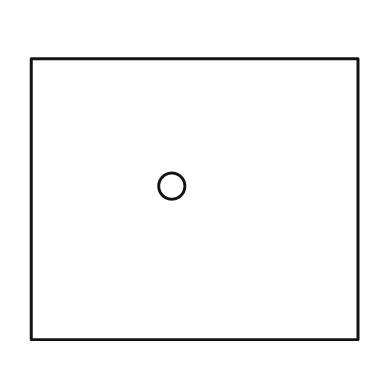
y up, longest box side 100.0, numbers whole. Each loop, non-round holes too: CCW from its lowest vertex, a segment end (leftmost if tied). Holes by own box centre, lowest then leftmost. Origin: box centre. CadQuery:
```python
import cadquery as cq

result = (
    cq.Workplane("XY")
    .moveTo(-50.0, -43.0)
    .lineTo(50.0, -43.0)
    .lineTo(50.0, 43.0)
    .lineTo(-50.0, 43.0)
    .close()
    .moveTo(-7.0, 4.0)
    .circle(4.0)
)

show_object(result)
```